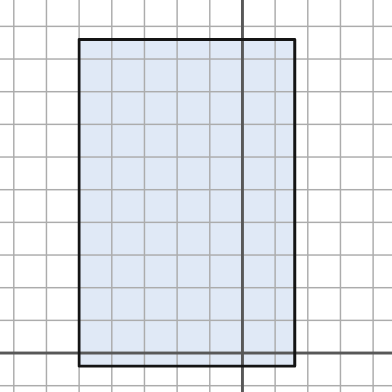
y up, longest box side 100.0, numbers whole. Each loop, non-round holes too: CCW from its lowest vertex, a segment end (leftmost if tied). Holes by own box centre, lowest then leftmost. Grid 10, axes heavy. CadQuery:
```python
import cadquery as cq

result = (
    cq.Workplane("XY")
    .moveTo(-50.0, -4.0)
    .lineTo(16.0, -4.0)
    .lineTo(16.0, 96.0)
    .lineTo(-50.0, 96.0)
    .close()
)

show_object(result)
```